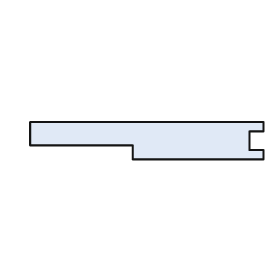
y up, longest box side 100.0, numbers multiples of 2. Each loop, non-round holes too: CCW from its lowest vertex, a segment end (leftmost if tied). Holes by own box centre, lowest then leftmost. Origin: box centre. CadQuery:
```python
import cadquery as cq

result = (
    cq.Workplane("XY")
    .moveTo(-6.0, -8.0)
    .lineTo(50.0, -8.0)
    .lineTo(50.0, -4.0)
    .lineTo(44.0, -4.0)
    .lineTo(44.0, 4.0)
    .lineTo(50.0, 4.0)
    .lineTo(50.0, 8.0)
    .lineTo(-50.0, 8.0)
    .lineTo(-50.0, -2.0)
    .lineTo(-6.0, -2.0)
    .close()
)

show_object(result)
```